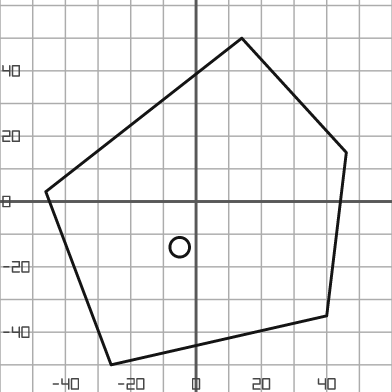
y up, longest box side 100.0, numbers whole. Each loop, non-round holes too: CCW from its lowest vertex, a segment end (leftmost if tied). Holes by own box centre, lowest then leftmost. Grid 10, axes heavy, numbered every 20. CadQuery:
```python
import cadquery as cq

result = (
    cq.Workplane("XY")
    .moveTo(-26.0, -50.0)
    .lineTo(40.0, -35.0)
    .lineTo(46.0, 15.0)
    .lineTo(14.0, 50.0)
    .lineTo(-46.0, 3.0)
    .close()
    .moveTo(-5.0, -14.0)
    .circle(3.0)
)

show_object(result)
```